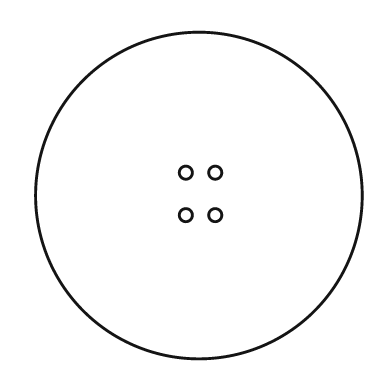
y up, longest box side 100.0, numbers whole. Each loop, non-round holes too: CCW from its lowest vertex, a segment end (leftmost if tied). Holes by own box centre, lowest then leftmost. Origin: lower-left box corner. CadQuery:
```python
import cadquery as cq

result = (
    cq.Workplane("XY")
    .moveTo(50.0, 50.0)
    .circle(50.0)
    .moveTo(46.0, 44.0)
    .circle(2.0)
    .moveTo(55.0, 44.0)
    .circle(2.0)
    .moveTo(46.0, 57.0)
    .circle(2.0)
    .moveTo(55.0, 57.0)
    .circle(2.0)
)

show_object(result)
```